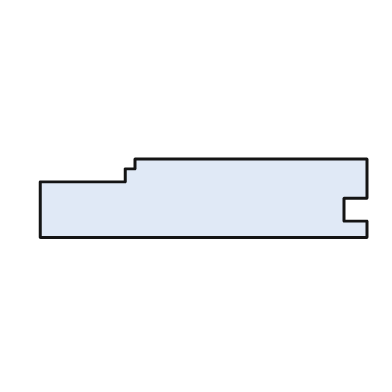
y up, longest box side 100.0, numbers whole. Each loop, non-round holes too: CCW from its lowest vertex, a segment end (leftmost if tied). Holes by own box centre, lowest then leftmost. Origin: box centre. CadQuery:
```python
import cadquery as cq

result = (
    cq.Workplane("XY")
    .moveTo(-50.0, -12.0)
    .lineTo(50.0, -12.0)
    .lineTo(50.0, -7.0)
    .lineTo(43.0, -7.0)
    .lineTo(43.0, 0.0)
    .lineTo(50.0, 0.0)
    .lineTo(50.0, 12.0)
    .lineTo(-21.0, 12.0)
    .lineTo(-21.0, 9.0)
    .lineTo(-24.0, 9.0)
    .lineTo(-24.0, 5.0)
    .lineTo(-50.0, 5.0)
    .close()
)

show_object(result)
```